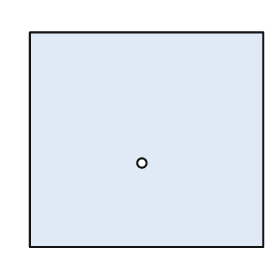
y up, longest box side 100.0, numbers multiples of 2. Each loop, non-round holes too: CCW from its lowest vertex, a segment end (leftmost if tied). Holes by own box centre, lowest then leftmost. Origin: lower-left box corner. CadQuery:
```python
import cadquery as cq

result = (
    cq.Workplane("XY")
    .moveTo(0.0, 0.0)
    .lineTo(100.0, 0.0)
    .lineTo(100.0, 92.0)
    .lineTo(0.0, 92.0)
    .close()
    .moveTo(48.0, 36.0)
    .circle(2.0)
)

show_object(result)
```